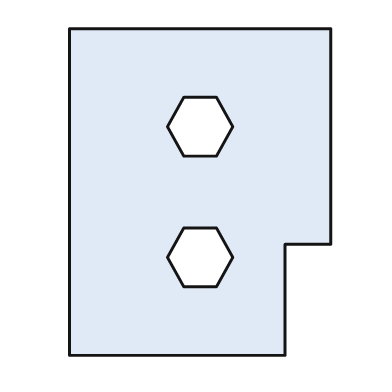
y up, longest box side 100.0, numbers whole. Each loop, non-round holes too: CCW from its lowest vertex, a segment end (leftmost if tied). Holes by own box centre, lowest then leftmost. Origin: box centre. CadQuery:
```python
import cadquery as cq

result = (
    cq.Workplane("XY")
    .moveTo(-40.0, -50.0)
    .lineTo(26.0, -50.0)
    .lineTo(26.0, -16.0)
    .lineTo(40.0, -16.0)
    .lineTo(40.0, 50.0)
    .lineTo(-40.0, 50.0)
    .close()
    .moveTo(-5.0, -29.0)
    .lineTo(5.0, -29.0)
    .lineTo(10.0, -20.0)
    .lineTo(5.0, -11.0)
    .lineTo(-5.0, -11.0)
    .lineTo(-10.0, -20.0)
    .close()
    .moveTo(-5.0, 11.0)
    .lineTo(5.0, 11.0)
    .lineTo(10.0, 20.0)
    .lineTo(5.0, 29.0)
    .lineTo(-5.0, 29.0)
    .lineTo(-10.0, 20.0)
    .close()
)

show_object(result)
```